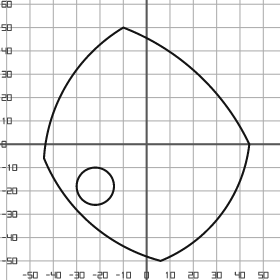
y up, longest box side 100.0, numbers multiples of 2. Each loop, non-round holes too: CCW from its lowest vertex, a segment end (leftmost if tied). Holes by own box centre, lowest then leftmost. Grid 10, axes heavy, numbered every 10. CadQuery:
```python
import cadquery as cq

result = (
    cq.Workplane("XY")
    .moveTo(6.0, -50.0)
    .threePointArc((32.0, -30.0), (44.0, 0.0))
    .threePointArc((22.0, 30.0), (-10.0, 50.0))
    .threePointArc((-34.0, 26.0), (-44.0, -6.0))
    .threePointArc((-24.0, -34.0), (6.0, -50.0))
    .close()
    .moveTo(-22.0, -18.0)
    .circle(8.0)
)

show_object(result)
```